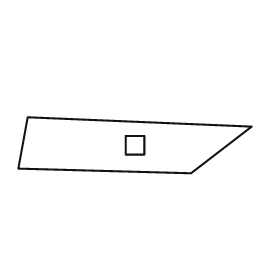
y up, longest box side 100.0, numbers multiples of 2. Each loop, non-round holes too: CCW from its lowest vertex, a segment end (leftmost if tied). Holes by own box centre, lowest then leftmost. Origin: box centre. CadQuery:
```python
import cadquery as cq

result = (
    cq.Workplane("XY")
    .moveTo(24.0, -12.0)
    .lineTo(50.0, 8.0)
    .lineTo(-46.0, 12.0)
    .lineTo(-50.0, -10.0)
    .close()
    .moveTo(-4.0, -4.0)
    .lineTo(4.0, -4.0)
    .lineTo(4.0, 4.0)
    .lineTo(-4.0, 4.0)
    .close()
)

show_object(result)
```